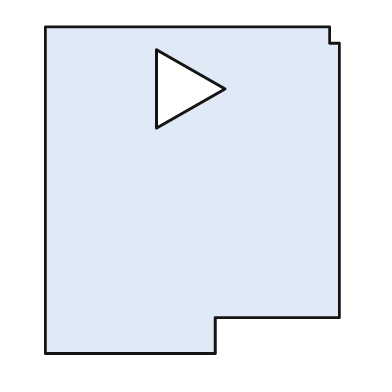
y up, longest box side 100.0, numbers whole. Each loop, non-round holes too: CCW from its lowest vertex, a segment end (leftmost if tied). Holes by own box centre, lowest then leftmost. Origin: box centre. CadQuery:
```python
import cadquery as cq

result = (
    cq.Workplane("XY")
    .moveTo(-45.0, -50.0)
    .lineTo(7.0, -50.0)
    .lineTo(7.0, -39.0)
    .lineTo(45.0, -39.0)
    .lineTo(45.0, 45.0)
    .lineTo(42.0, 45.0)
    .lineTo(42.0, 50.0)
    .lineTo(-45.0, 50.0)
    .close()
    .moveTo(-11.0, 19.0)
    .lineTo(10.0, 31.0)
    .lineTo(-11.0, 43.0)
    .close()
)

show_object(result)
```